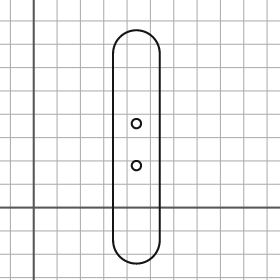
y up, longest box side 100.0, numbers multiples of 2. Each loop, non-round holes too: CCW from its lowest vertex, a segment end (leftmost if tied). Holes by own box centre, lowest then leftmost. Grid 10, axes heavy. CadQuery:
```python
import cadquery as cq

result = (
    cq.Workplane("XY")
    .moveTo(34.0, -14.0)
    .threePointArc((44.0, -24.0), (54.0, -14.0))
    .lineTo(54.0, 66.0)
    .threePointArc((44.0, 76.0), (34.0, 66.0))
    .close()
    .moveTo(44.0, 18.0)
    .circle(2.0)
    .moveTo(44.0, 36.0)
    .circle(2.0)
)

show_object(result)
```